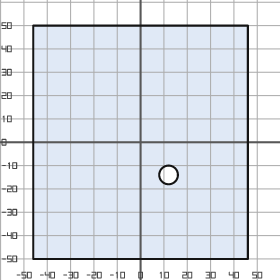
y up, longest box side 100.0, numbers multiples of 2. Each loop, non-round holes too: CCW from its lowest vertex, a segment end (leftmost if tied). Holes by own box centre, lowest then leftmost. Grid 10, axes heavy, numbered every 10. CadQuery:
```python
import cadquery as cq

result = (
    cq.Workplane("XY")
    .moveTo(-46.0, -50.0)
    .lineTo(46.0, -50.0)
    .lineTo(46.0, 50.0)
    .lineTo(-46.0, 50.0)
    .close()
    .moveTo(12.0, -14.0)
    .circle(4.0)
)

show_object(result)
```